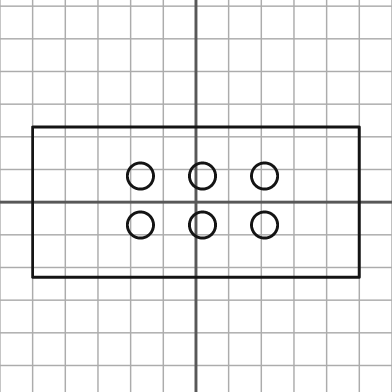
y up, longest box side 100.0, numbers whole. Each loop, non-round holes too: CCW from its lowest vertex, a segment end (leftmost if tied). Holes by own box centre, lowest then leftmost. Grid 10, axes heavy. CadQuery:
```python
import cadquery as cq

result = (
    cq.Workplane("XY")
    .moveTo(-50.0, -23.0)
    .lineTo(50.0, -23.0)
    .lineTo(50.0, 23.0)
    .lineTo(-50.0, 23.0)
    .close()
    .moveTo(-17.0, -7.0)
    .circle(4.0)
    .moveTo(2.0, -7.0)
    .circle(4.0)
    .moveTo(21.0, -7.0)
    .circle(4.0)
    .moveTo(-17.0, 8.0)
    .circle(4.0)
    .moveTo(2.0, 8.0)
    .circle(4.0)
    .moveTo(21.0, 8.0)
    .circle(4.0)
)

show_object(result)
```